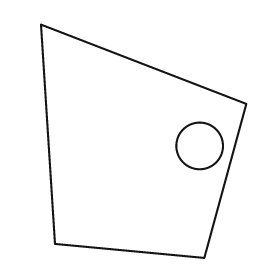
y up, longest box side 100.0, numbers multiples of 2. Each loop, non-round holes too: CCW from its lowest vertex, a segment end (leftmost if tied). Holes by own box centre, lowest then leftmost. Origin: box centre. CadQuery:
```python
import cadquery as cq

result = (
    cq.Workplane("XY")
    .moveTo(26.0, -50.0)
    .lineTo(44.0, 16.0)
    .lineTo(-44.0, 50.0)
    .lineTo(-38.0, -44.0)
    .close()
    .moveTo(24.0, -2.0)
    .circle(10.0)
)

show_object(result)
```